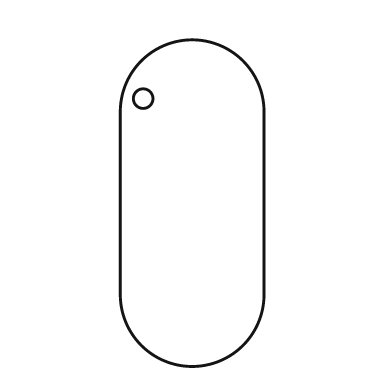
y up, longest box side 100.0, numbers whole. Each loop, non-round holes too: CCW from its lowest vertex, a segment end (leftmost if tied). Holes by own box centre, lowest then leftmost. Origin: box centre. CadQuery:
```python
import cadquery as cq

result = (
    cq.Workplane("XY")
    .moveTo(-22.0, -28.0)
    .threePointArc((0.0, -50.0), (22.0, -28.0))
    .lineTo(22.0, 28.0)
    .threePointArc((0.0, 50.0), (-22.0, 28.0))
    .close()
    .moveTo(-15.0, 32.0)
    .circle(3.0)
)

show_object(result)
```